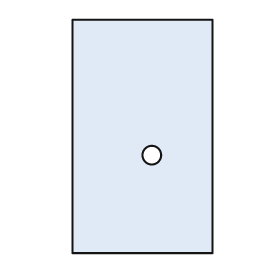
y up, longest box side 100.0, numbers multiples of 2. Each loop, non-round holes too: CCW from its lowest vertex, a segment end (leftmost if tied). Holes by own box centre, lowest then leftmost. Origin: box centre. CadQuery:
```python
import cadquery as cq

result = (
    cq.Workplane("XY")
    .moveTo(-30.0, -50.0)
    .lineTo(30.0, -50.0)
    .lineTo(30.0, 50.0)
    .lineTo(-30.0, 50.0)
    .close()
    .moveTo(4.0, -8.0)
    .circle(4.0)
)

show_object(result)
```